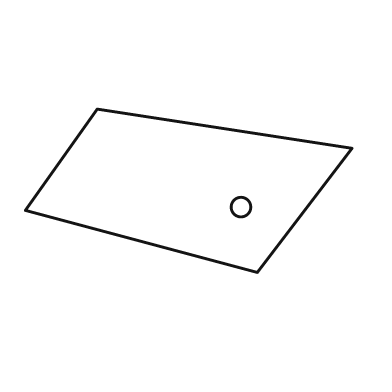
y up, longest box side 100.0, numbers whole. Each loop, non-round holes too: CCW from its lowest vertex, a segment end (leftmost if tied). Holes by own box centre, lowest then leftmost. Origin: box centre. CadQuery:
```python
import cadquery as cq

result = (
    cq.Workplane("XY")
    .moveTo(21.0, -25.0)
    .lineTo(50.0, 13.0)
    .lineTo(-28.0, 25.0)
    .lineTo(-50.0, -6.0)
    .close()
    .moveTo(16.0, -5.0)
    .circle(3.0)
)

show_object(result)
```